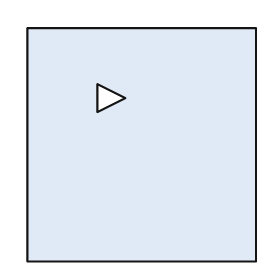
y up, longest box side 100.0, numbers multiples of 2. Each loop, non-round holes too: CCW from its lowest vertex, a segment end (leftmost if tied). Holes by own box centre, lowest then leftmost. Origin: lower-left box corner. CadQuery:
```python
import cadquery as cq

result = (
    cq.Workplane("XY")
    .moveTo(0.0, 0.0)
    .lineTo(98.0, 0.0)
    .lineTo(98.0, 100.0)
    .lineTo(0.0, 100.0)
    .close()
    .moveTo(30.0, 64.0)
    .lineTo(42.0, 70.0)
    .lineTo(30.0, 76.0)
    .close()
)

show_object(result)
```